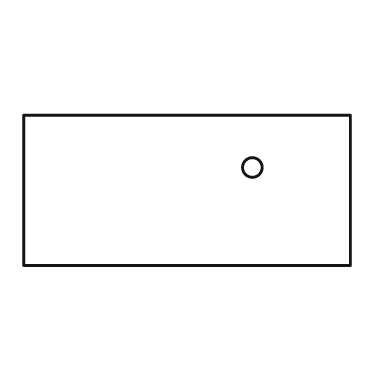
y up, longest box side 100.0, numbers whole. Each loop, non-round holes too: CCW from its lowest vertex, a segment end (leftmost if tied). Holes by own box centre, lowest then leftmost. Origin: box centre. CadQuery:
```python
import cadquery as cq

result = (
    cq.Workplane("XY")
    .moveTo(-50.0, -23.0)
    .lineTo(50.0, -23.0)
    .lineTo(50.0, 23.0)
    .lineTo(-50.0, 23.0)
    .close()
    .moveTo(20.0, 7.0)
    .circle(3.0)
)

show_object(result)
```